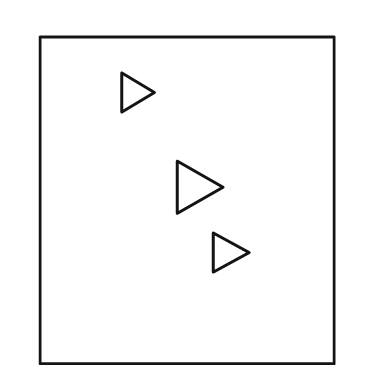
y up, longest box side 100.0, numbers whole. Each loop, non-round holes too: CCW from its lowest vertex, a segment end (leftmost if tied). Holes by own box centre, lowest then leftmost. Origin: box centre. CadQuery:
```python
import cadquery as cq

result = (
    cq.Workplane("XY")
    .moveTo(-45.0, -50.0)
    .lineTo(45.0, -50.0)
    .lineTo(45.0, 50.0)
    .lineTo(-45.0, 50.0)
    .close()
    .moveTo(8.0, -22.0)
    .lineTo(19.0, -16.0)
    .lineTo(8.0, -10.0)
    .close()
    .moveTo(-3.0, -4.0)
    .lineTo(11.0, 4.0)
    .lineTo(-3.0, 12.0)
    .close()
    .moveTo(-20.0, 27.0)
    .lineTo(-10.0, 33.0)
    .lineTo(-20.0, 39.0)
    .close()
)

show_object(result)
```